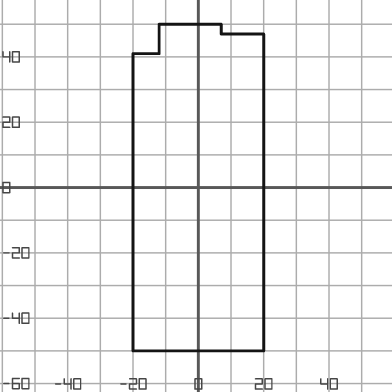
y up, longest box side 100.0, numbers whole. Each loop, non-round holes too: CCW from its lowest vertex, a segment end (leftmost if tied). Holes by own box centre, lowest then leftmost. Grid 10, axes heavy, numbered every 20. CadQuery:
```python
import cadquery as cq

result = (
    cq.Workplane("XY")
    .moveTo(-20.0, -50.0)
    .lineTo(20.0, -50.0)
    .lineTo(20.0, 47.0)
    .lineTo(7.0, 47.0)
    .lineTo(7.0, 50.0)
    .lineTo(-12.0, 50.0)
    .lineTo(-12.0, 41.0)
    .lineTo(-20.0, 41.0)
    .close()
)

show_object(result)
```